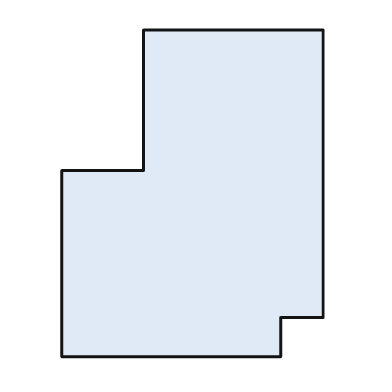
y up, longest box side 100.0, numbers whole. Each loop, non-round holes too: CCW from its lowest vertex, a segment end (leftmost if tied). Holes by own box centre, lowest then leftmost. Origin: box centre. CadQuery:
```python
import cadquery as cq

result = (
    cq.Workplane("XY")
    .moveTo(-40.0, -50.0)
    .lineTo(27.0, -50.0)
    .lineTo(27.0, -38.0)
    .lineTo(40.0, -38.0)
    .lineTo(40.0, 50.0)
    .lineTo(-15.0, 50.0)
    .lineTo(-15.0, 7.0)
    .lineTo(-40.0, 7.0)
    .close()
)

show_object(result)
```